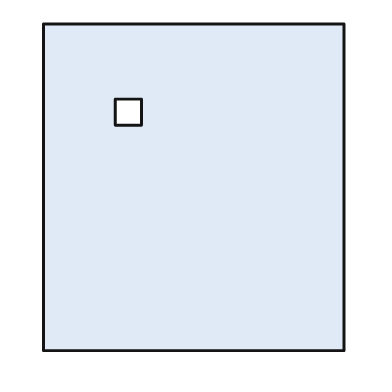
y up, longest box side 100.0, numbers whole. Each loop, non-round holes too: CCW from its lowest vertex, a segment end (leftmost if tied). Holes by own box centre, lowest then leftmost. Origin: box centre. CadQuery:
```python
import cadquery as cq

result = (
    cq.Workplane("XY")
    .moveTo(-46.0, -50.0)
    .lineTo(46.0, -50.0)
    .lineTo(46.0, 50.0)
    .lineTo(-46.0, 50.0)
    .close()
    .moveTo(-24.0, 19.0)
    .lineTo(-16.0, 19.0)
    .lineTo(-16.0, 27.0)
    .lineTo(-24.0, 27.0)
    .close()
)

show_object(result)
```